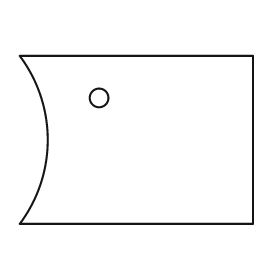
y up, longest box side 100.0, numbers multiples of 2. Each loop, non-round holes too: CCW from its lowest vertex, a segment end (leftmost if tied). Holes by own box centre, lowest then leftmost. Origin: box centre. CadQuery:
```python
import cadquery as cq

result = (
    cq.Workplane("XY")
    .moveTo(-50.0, -36.0)
    .lineTo(50.0, -36.0)
    .lineTo(50.0, 36.0)
    .lineTo(-50.0, 36.0)
    .threePointArc((-38.0, 0.0), (-50.0, -36.0))
    .close()
    .moveTo(-16.0, 18.0)
    .circle(4.0)
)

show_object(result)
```